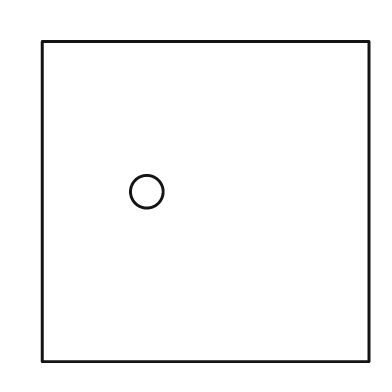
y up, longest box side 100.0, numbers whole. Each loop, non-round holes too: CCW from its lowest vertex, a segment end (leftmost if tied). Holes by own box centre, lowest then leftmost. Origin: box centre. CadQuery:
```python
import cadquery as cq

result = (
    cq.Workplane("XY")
    .moveTo(-50.0, -49.0)
    .lineTo(50.0, -49.0)
    .lineTo(50.0, 49.0)
    .lineTo(-50.0, 49.0)
    .close()
    .moveTo(-18.0, 3.0)
    .circle(5.0)
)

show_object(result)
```